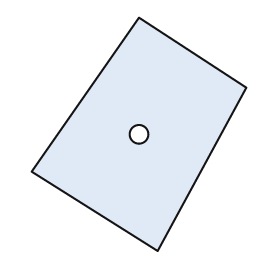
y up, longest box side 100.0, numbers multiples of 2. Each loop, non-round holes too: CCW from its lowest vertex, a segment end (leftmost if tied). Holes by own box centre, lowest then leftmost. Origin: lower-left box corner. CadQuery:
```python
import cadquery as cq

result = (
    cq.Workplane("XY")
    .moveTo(54.0, 0.0)
    .lineTo(92.0, 70.0)
    .lineTo(46.0, 100.0)
    .lineTo(0.0, 34.0)
    .close()
    .moveTo(46.0, 50.0)
    .circle(4.0)
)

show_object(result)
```